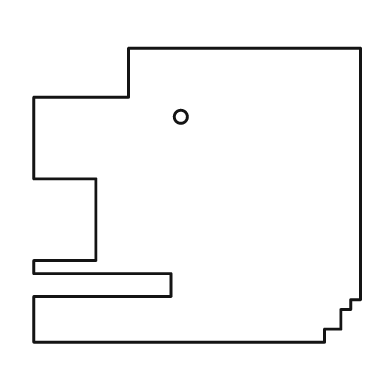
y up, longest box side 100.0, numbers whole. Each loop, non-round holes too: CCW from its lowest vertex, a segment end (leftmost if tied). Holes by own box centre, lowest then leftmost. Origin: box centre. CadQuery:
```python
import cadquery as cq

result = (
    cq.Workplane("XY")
    .moveTo(-50.0, -45.0)
    .lineTo(39.0, -45.0)
    .lineTo(39.0, -41.0)
    .lineTo(44.0, -41.0)
    .lineTo(44.0, -35.0)
    .lineTo(47.0, -35.0)
    .lineTo(47.0, -32.0)
    .lineTo(50.0, -32.0)
    .lineTo(50.0, 45.0)
    .lineTo(-21.0, 45.0)
    .lineTo(-21.0, 30.0)
    .lineTo(-50.0, 30.0)
    .lineTo(-50.0, 5.0)
    .lineTo(-31.0, 5.0)
    .lineTo(-31.0, -20.0)
    .lineTo(-50.0, -20.0)
    .lineTo(-50.0, -24.0)
    .lineTo(-8.0, -24.0)
    .lineTo(-8.0, -31.0)
    .lineTo(-50.0, -31.0)
    .close()
    .moveTo(-5.0, 24.0)
    .circle(2.0)
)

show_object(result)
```